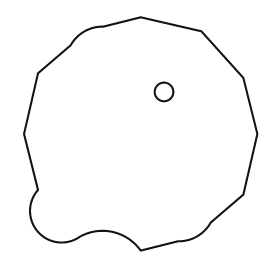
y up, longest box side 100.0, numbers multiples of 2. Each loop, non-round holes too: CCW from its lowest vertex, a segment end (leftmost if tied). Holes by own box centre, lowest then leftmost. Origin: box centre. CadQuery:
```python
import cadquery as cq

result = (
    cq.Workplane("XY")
    .moveTo(0.0, -50.0)
    .lineTo(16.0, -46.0)
    .threePointArc((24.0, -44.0), (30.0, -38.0))
    .lineTo(44.0, -26.0)
    .lineTo(50.0, 0.0)
    .lineTo(44.0, 24.0)
    .lineTo(26.0, 44.0)
    .lineTo(0.0, 50.0)
    .lineTo(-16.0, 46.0)
    .threePointArc((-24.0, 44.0), (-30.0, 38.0))
    .lineTo(-44.0, 26.0)
    .lineTo(-50.0, 0.0)
    .lineTo(-44.0, -24.0)
    .threePointArc((-44.0, -42.0), (-26.0, -44.0))
    .threePointArc((-12.0, -42.0), (0.0, -50.0))
    .close()
    .moveTo(10.0, 18.0)
    .circle(4.0)
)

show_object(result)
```